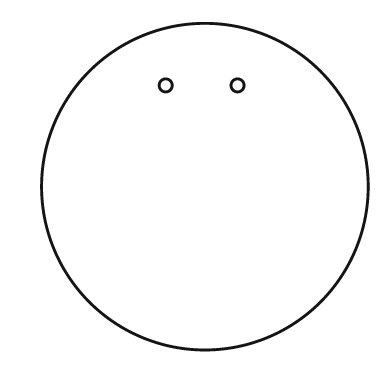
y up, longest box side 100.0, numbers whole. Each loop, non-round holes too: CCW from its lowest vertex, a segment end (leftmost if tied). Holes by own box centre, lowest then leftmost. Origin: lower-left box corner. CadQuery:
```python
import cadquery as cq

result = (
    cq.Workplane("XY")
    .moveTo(50.0, 50.0)
    .circle(50.0)
    .moveTo(38.0, 81.0)
    .circle(2.0)
    .moveTo(60.0, 81.0)
    .circle(2.0)
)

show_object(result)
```